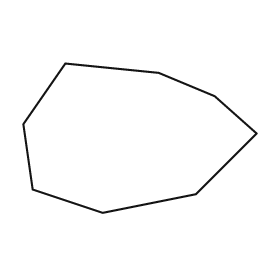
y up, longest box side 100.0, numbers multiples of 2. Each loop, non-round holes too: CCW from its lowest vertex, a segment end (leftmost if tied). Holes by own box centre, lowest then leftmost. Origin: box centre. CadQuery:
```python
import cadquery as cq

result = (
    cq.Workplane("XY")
    .moveTo(-16.0, -32.0)
    .lineTo(24.0, -24.0)
    .lineTo(50.0, 2.0)
    .lineTo(32.0, 18.0)
    .lineTo(8.0, 28.0)
    .lineTo(-32.0, 32.0)
    .lineTo(-50.0, 6.0)
    .lineTo(-46.0, -22.0)
    .close()
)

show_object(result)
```